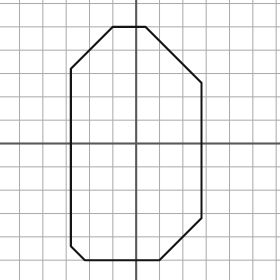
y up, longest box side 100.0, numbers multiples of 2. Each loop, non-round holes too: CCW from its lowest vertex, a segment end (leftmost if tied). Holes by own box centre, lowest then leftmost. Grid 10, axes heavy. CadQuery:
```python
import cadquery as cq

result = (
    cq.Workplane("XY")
    .moveTo(-22.0, -50.0)
    .lineTo(10.0, -50.0)
    .lineTo(28.0, -32.0)
    .lineTo(28.0, 26.0)
    .lineTo(4.0, 50.0)
    .lineTo(-10.0, 50.0)
    .lineTo(-28.0, 32.0)
    .lineTo(-28.0, -44.0)
    .close()
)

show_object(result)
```